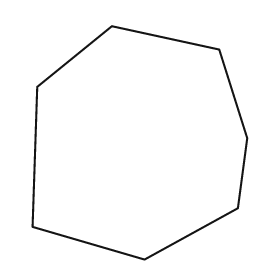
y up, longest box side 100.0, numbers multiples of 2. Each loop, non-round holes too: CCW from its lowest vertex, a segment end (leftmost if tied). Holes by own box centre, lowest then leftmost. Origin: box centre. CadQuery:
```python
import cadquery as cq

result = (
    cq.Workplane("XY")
    .moveTo(2.0, -50.0)
    .lineTo(42.0, -28.0)
    .lineTo(46.0, 2.0)
    .lineTo(34.0, 40.0)
    .lineTo(-12.0, 50.0)
    .lineTo(-44.0, 24.0)
    .lineTo(-46.0, -36.0)
    .close()
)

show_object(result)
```